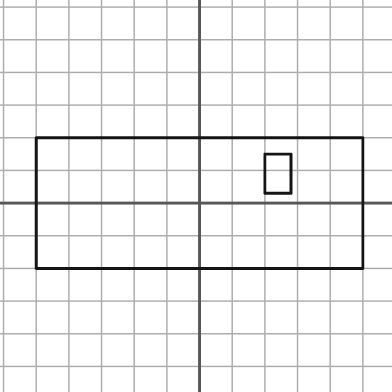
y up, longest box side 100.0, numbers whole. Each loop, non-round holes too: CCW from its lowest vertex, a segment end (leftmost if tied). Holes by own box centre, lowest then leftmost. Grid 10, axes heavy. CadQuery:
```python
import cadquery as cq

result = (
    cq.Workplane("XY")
    .moveTo(-50.0, -20.0)
    .lineTo(50.0, -20.0)
    .lineTo(50.0, 20.0)
    .lineTo(-50.0, 20.0)
    .close()
    .moveTo(20.0, 3.0)
    .lineTo(28.0, 3.0)
    .lineTo(28.0, 15.0)
    .lineTo(20.0, 15.0)
    .close()
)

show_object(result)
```